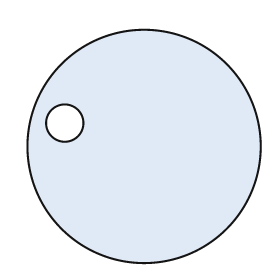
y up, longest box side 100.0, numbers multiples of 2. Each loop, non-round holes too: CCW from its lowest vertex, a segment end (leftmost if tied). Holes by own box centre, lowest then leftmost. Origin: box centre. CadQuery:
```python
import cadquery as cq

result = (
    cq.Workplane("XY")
    .moveTo(0.0, 0.0)
    .circle(50.0)
    .moveTo(-34.0, 10.0)
    .circle(8.0)
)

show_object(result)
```